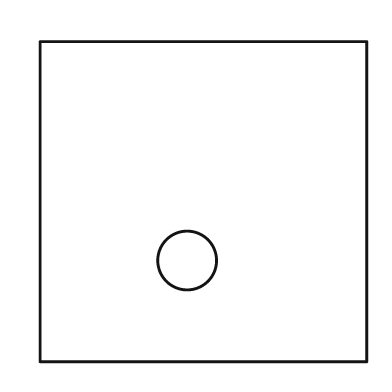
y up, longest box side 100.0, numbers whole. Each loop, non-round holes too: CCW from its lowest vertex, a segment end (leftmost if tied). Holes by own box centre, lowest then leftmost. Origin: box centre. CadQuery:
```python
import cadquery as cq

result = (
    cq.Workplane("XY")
    .moveTo(-50.0, -49.0)
    .lineTo(50.0, -49.0)
    .lineTo(50.0, 49.0)
    .lineTo(-50.0, 49.0)
    .close()
    .moveTo(-5.0, -18.0)
    .circle(9.0)
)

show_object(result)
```